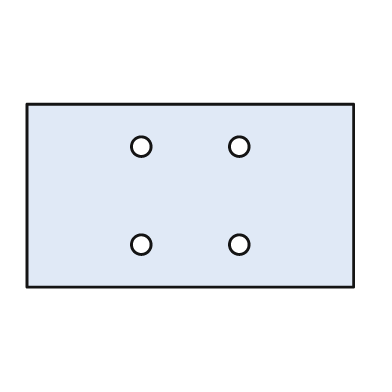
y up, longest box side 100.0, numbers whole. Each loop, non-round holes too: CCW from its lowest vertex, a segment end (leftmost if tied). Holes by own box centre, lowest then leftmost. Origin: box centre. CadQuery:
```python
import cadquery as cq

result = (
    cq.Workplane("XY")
    .moveTo(-50.0, -28.0)
    .lineTo(50.0, -28.0)
    .lineTo(50.0, 28.0)
    .lineTo(-50.0, 28.0)
    .close()
    .moveTo(-15.0, -15.0)
    .circle(3.0)
    .moveTo(15.0, -15.0)
    .circle(3.0)
    .moveTo(-15.0, 15.0)
    .circle(3.0)
    .moveTo(15.0, 15.0)
    .circle(3.0)
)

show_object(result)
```